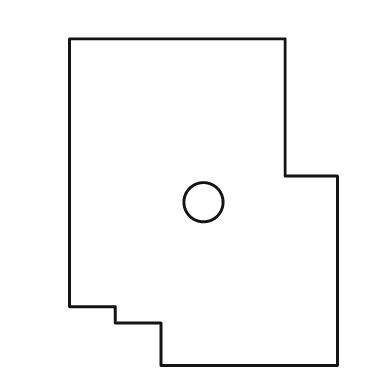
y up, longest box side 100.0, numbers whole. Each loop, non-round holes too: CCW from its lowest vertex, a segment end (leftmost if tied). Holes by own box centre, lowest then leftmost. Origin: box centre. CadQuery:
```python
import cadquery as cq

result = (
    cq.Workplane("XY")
    .moveTo(-13.0, -50.0)
    .lineTo(41.0, -50.0)
    .lineTo(41.0, 8.0)
    .lineTo(25.0, 8.0)
    .lineTo(25.0, 50.0)
    .lineTo(-41.0, 50.0)
    .lineTo(-41.0, -32.0)
    .lineTo(-27.0, -32.0)
    .lineTo(-27.0, -37.0)
    .lineTo(-13.0, -37.0)
    .close()
    .moveTo(0.0, 0.0)
    .circle(6.0)
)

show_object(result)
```